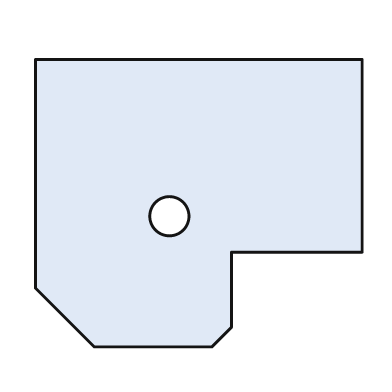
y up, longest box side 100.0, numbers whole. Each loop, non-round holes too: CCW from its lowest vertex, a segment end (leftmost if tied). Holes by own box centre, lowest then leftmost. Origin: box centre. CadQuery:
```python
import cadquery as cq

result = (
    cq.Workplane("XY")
    .moveTo(-32.0, -44.0)
    .lineTo(4.0, -44.0)
    .lineTo(10.0, -38.0)
    .lineTo(10.0, -15.0)
    .lineTo(50.0, -15.0)
    .lineTo(50.0, 44.0)
    .lineTo(-50.0, 44.0)
    .lineTo(-50.0, -26.0)
    .close()
    .moveTo(-9.0, -4.0)
    .circle(6.0)
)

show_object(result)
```